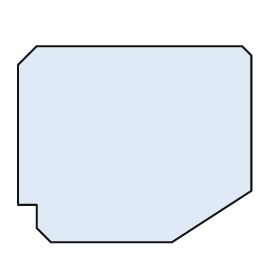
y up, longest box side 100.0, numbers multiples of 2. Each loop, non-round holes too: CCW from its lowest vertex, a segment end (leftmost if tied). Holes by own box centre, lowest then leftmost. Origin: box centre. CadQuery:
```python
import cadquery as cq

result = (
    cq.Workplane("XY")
    .moveTo(-36.0, -42.0)
    .lineTo(16.0, -42.0)
    .lineTo(50.0, -20.0)
    .lineTo(50.0, 38.0)
    .lineTo(46.0, 42.0)
    .lineTo(-42.0, 42.0)
    .lineTo(-50.0, 34.0)
    .lineTo(-50.0, -26.0)
    .lineTo(-42.0, -26.0)
    .lineTo(-42.0, -36.0)
    .close()
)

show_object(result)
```